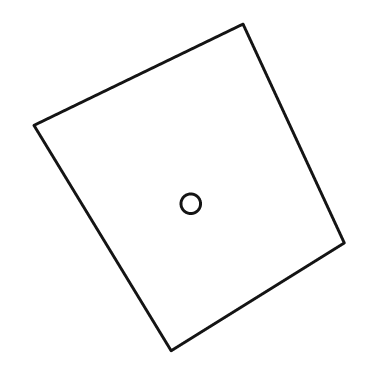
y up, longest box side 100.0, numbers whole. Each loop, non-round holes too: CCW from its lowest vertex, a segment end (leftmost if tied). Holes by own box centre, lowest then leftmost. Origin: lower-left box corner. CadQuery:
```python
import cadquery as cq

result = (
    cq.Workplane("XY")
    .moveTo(42.0, 0.0)
    .lineTo(95.0, 33.0)
    .lineTo(64.0, 100.0)
    .lineTo(0.0, 69.0)
    .close()
    .moveTo(48.0, 45.0)
    .circle(3.0)
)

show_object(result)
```